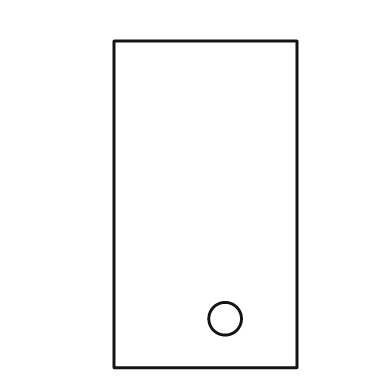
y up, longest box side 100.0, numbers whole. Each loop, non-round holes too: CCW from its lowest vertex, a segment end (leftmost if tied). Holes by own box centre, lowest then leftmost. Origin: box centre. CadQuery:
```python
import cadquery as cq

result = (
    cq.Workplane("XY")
    .moveTo(-28.0, -50.0)
    .lineTo(28.0, -50.0)
    .lineTo(28.0, 50.0)
    .lineTo(-28.0, 50.0)
    .close()
    .moveTo(6.0, -35.0)
    .circle(5.0)
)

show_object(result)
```